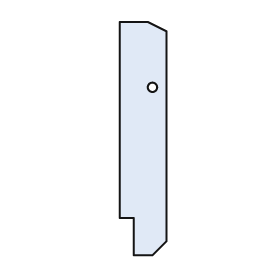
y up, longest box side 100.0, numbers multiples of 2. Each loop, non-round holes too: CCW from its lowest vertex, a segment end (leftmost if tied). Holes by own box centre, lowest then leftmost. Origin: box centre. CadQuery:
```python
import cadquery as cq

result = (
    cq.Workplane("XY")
    .moveTo(-4.0, -50.0)
    .lineTo(4.0, -50.0)
    .lineTo(10.0, -44.0)
    .lineTo(10.0, 46.0)
    .lineTo(2.0, 50.0)
    .lineTo(-10.0, 50.0)
    .lineTo(-10.0, -34.0)
    .lineTo(-4.0, -34.0)
    .close()
    .moveTo(4.0, 22.0)
    .circle(2.0)
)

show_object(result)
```